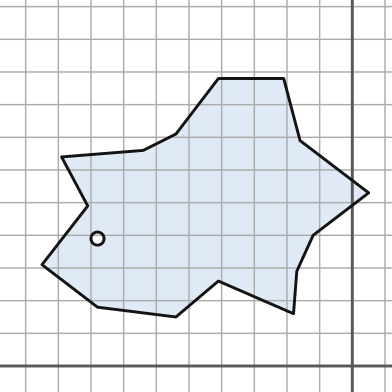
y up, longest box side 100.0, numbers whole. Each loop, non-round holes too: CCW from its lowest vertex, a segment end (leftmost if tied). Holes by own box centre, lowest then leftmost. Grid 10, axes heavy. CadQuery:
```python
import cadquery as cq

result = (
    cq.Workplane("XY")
    .moveTo(-54.0, 15.0)
    .lineTo(-41.0, 26.0)
    .lineTo(-18.0, 16.0)
    .lineTo(-17.0, 29.0)
    .lineTo(-12.0, 40.0)
    .lineTo(5.0, 53.0)
    .lineTo(-16.0, 69.0)
    .lineTo(-21.0, 88.0)
    .lineTo(-41.0, 88.0)
    .lineTo(-54.0, 71.0)
    .lineTo(-64.0, 66.0)
    .lineTo(-89.0, 64.0)
    .lineTo(-81.0, 49.0)
    .lineTo(-95.0, 31.0)
    .lineTo(-78.0, 18.0)
    .close()
    .moveTo(-78.0, 39.0)
    .circle(2.0)
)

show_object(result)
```